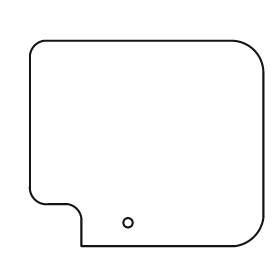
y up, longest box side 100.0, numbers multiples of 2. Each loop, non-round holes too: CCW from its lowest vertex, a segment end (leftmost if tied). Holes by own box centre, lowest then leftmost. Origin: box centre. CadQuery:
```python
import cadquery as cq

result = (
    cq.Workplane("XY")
    .moveTo(-28.0, -44.0)
    .lineTo(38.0, -44.0)
    .threePointArc((46.0, -40.0), (50.0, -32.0))
    .lineTo(50.0, 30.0)
    .threePointArc((46.0, 40.0), (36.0, 44.0))
    .lineTo(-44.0, 44.0)
    .threePointArc((-48.0, 42.0), (-50.0, 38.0))
    .lineTo(-50.0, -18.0)
    .threePointArc((-48.0, -24.0), (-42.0, -26.0))
    .lineTo(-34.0, -26.0)
    .threePointArc((-30.0, -28.0), (-28.0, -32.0))
    .close()
    .moveTo(-8.0, -34.0)
    .circle(2.0)
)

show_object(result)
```